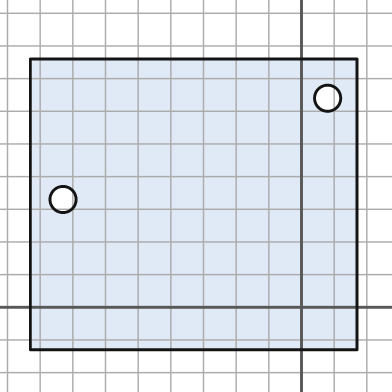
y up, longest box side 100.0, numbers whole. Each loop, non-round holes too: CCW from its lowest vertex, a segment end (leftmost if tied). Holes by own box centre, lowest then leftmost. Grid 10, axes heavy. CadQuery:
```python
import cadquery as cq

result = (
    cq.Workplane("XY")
    .moveTo(-83.0, -13.0)
    .lineTo(17.0, -13.0)
    .lineTo(17.0, 76.0)
    .lineTo(-83.0, 76.0)
    .close()
    .moveTo(-73.0, 33.0)
    .circle(4.0)
    .moveTo(8.0, 64.0)
    .circle(4.0)
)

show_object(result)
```